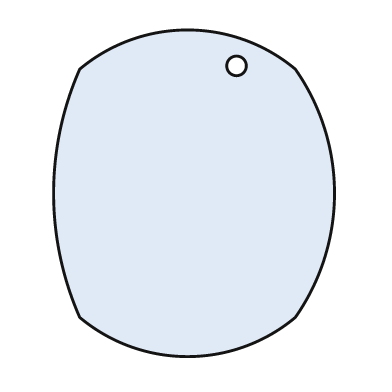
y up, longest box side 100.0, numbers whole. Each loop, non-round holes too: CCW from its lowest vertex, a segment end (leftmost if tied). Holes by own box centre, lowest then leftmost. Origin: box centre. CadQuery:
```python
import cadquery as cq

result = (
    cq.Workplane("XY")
    .moveTo(-35.0, -38.0)
    .threePointArc((-2.0, -50.0), (31.0, -38.0))
    .threePointArc((43.0, 0.0), (31.0, 38.0))
    .threePointArc((-2.0, 50.0), (-35.0, 38.0))
    .threePointArc((-43.0, 0.0), (-35.0, -38.0))
    .close()
    .moveTo(13.0, 39.0)
    .circle(3.0)
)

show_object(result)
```